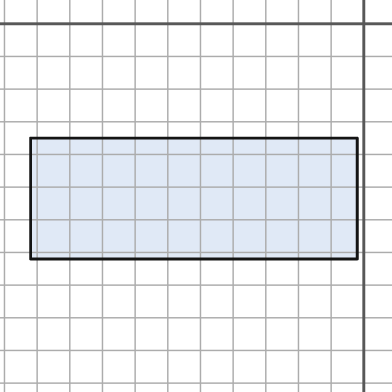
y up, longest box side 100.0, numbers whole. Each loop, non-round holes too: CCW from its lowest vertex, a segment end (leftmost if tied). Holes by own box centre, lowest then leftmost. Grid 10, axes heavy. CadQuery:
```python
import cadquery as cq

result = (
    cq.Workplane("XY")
    .moveTo(-102.0, -72.0)
    .lineTo(-2.0, -72.0)
    .lineTo(-2.0, -35.0)
    .lineTo(-102.0, -35.0)
    .close()
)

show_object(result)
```